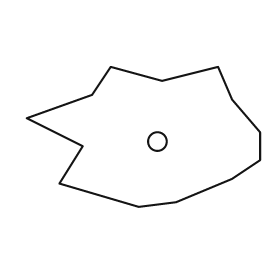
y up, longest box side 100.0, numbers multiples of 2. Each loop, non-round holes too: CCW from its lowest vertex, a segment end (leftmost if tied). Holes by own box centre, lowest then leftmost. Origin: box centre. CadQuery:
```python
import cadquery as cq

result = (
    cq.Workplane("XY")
    .moveTo(-2.0, -30.0)
    .lineTo(14.0, -28.0)
    .lineTo(38.0, -18.0)
    .lineTo(50.0, -10.0)
    .lineTo(50.0, 2.0)
    .lineTo(38.0, 16.0)
    .lineTo(32.0, 30.0)
    .lineTo(8.0, 24.0)
    .lineTo(-14.0, 30.0)
    .lineTo(-22.0, 18.0)
    .lineTo(-50.0, 8.0)
    .lineTo(-26.0, -4.0)
    .lineTo(-36.0, -20.0)
    .close()
    .moveTo(6.0, -2.0)
    .circle(4.0)
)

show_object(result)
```